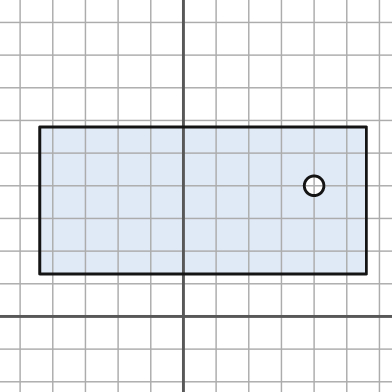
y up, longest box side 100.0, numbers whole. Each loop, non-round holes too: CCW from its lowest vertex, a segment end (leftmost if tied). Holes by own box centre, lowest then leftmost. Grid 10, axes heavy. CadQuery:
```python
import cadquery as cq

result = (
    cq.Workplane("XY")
    .moveTo(-44.0, 13.0)
    .lineTo(56.0, 13.0)
    .lineTo(56.0, 58.0)
    .lineTo(-44.0, 58.0)
    .close()
    .moveTo(40.0, 40.0)
    .circle(3.0)
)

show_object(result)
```